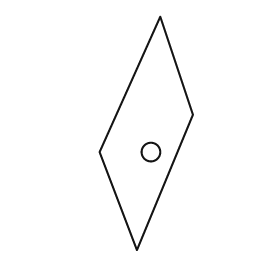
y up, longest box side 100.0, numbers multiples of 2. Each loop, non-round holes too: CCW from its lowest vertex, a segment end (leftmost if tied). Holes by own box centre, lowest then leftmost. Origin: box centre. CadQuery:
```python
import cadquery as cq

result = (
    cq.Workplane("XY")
    .moveTo(-4.0, -50.0)
    .lineTo(20.0, 8.0)
    .lineTo(6.0, 50.0)
    .lineTo(-20.0, -8.0)
    .close()
    .moveTo(2.0, -8.0)
    .circle(4.0)
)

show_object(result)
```